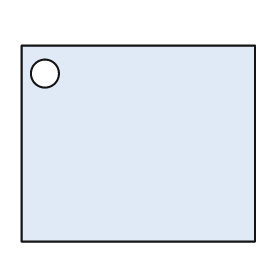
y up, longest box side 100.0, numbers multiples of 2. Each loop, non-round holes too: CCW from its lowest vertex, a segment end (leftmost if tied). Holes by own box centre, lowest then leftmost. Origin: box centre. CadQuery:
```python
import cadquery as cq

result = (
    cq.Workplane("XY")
    .moveTo(-50.0, -42.0)
    .lineTo(50.0, -42.0)
    .lineTo(50.0, 42.0)
    .lineTo(-50.0, 42.0)
    .close()
    .moveTo(-40.0, 30.0)
    .circle(6.0)
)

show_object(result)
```